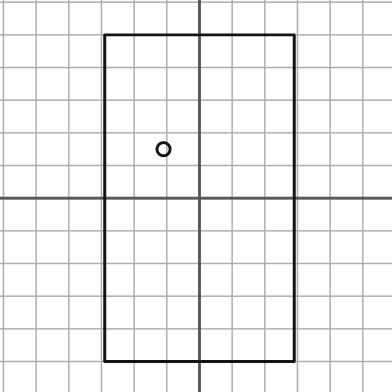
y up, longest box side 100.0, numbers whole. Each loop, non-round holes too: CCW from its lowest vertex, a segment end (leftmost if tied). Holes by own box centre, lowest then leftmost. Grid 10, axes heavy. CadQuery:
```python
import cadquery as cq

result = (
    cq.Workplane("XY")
    .moveTo(-29.0, -50.0)
    .lineTo(29.0, -50.0)
    .lineTo(29.0, 50.0)
    .lineTo(-29.0, 50.0)
    .close()
    .moveTo(-11.0, 15.0)
    .circle(2.0)
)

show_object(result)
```